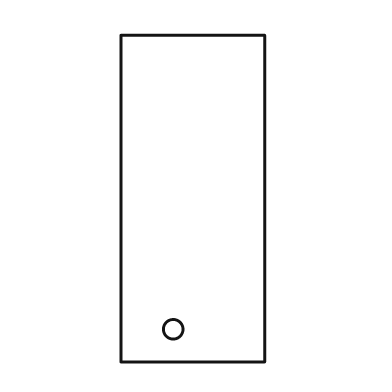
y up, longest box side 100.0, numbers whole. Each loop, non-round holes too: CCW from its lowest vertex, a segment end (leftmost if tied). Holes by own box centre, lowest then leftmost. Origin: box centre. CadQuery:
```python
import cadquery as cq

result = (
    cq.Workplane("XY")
    .moveTo(-22.0, -50.0)
    .lineTo(22.0, -50.0)
    .lineTo(22.0, 50.0)
    .lineTo(-22.0, 50.0)
    .close()
    .moveTo(-6.0, -40.0)
    .circle(3.0)
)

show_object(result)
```